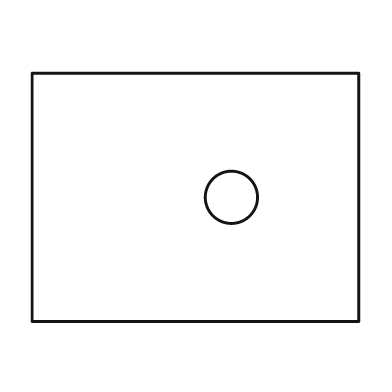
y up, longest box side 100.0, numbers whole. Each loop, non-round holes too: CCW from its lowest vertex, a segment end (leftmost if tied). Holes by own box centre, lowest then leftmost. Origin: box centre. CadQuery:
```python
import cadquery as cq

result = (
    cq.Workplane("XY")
    .moveTo(-50.0, -38.0)
    .lineTo(50.0, -38.0)
    .lineTo(50.0, 38.0)
    .lineTo(-50.0, 38.0)
    .close()
    .moveTo(11.0, 0.0)
    .circle(8.0)
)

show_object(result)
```